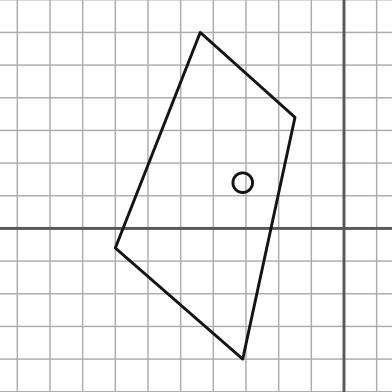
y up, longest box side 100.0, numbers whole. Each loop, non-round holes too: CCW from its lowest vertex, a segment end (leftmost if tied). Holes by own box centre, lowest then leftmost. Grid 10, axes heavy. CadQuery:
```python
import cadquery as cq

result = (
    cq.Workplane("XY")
    .moveTo(-31.0, -40.0)
    .lineTo(-15.0, 34.0)
    .lineTo(-44.0, 60.0)
    .lineTo(-70.0, -6.0)
    .close()
    .moveTo(-31.0, 14.0)
    .circle(3.0)
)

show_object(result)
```